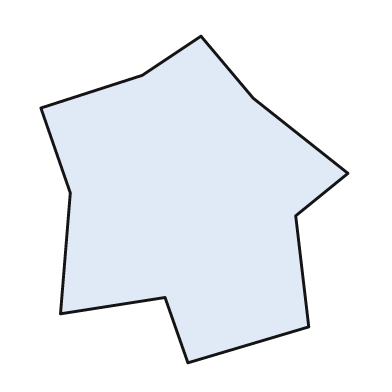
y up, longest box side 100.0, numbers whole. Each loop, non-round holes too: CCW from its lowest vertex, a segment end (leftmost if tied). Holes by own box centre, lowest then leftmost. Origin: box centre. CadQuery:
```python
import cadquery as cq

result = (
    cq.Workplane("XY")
    .moveTo(-2.0, -50.0)
    .lineTo(35.0, -39.0)
    .lineTo(31.0, -5.0)
    .lineTo(47.0, 8.0)
    .lineTo(18.0, 31.0)
    .lineTo(2.0, 50.0)
    .lineTo(-16.0, 38.0)
    .lineTo(-47.0, 28.0)
    .lineTo(-38.0, 2.0)
    .lineTo(-41.0, -35.0)
    .lineTo(-9.0, -30.0)
    .close()
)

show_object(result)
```